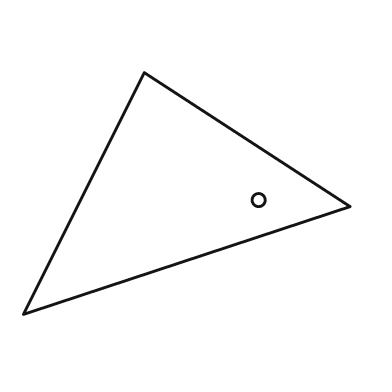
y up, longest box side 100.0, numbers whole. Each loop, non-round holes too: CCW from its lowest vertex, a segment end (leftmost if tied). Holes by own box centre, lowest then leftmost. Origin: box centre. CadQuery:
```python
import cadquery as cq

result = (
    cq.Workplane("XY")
    .moveTo(-50.0, -37.0)
    .lineTo(50.0, -4.0)
    .lineTo(-13.0, 37.0)
    .close()
    .moveTo(22.0, -2.0)
    .circle(2.0)
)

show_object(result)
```